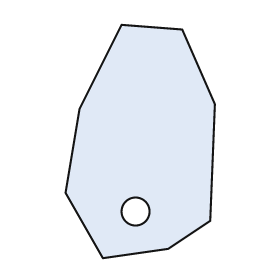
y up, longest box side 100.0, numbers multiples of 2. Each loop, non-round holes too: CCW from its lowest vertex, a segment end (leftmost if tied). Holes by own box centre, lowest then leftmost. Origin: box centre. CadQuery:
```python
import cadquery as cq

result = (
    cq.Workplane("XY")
    .moveTo(-16.0, -50.0)
    .lineTo(12.0, -46.0)
    .lineTo(30.0, -34.0)
    .lineTo(32.0, 16.0)
    .lineTo(18.0, 48.0)
    .lineTo(-8.0, 50.0)
    .lineTo(-26.0, 14.0)
    .lineTo(-32.0, -22.0)
    .close()
    .moveTo(-2.0, -30.0)
    .circle(6.0)
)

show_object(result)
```